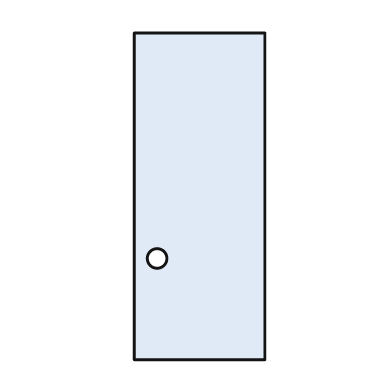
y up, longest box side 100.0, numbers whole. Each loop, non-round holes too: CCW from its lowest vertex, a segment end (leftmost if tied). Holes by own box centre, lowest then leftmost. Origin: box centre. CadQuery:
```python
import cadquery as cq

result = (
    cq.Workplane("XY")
    .moveTo(-20.0, -50.0)
    .lineTo(20.0, -50.0)
    .lineTo(20.0, 50.0)
    .lineTo(-20.0, 50.0)
    .close()
    .moveTo(-13.0, -19.0)
    .circle(3.0)
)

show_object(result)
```